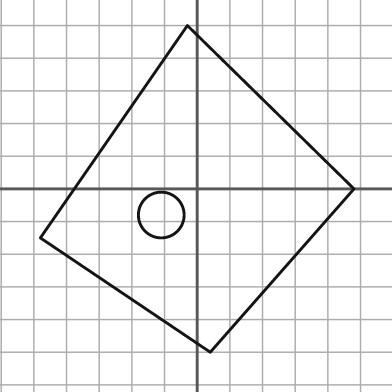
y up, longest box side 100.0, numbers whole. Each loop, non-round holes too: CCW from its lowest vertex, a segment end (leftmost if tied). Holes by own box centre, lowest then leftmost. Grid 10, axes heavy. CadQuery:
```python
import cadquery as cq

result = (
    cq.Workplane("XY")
    .moveTo(4.0, -50.0)
    .lineTo(48.0, 0.0)
    .lineTo(-3.0, 50.0)
    .lineTo(-48.0, -15.0)
    .close()
    .moveTo(-11.0, -8.0)
    .circle(7.0)
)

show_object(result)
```